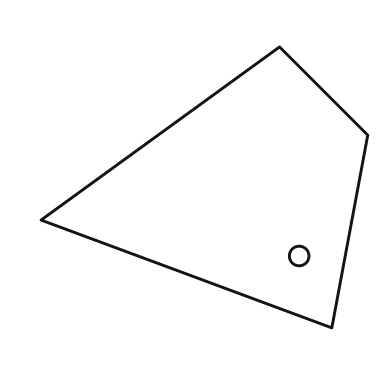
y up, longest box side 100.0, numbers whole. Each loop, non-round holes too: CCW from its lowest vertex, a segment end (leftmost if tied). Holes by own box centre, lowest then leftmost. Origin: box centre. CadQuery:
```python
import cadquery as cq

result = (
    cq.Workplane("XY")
    .moveTo(39.0, -43.0)
    .lineTo(50.0, 16.0)
    .lineTo(23.0, 43.0)
    .lineTo(-50.0, -10.0)
    .close()
    .moveTo(29.0, -21.0)
    .circle(3.0)
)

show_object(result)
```